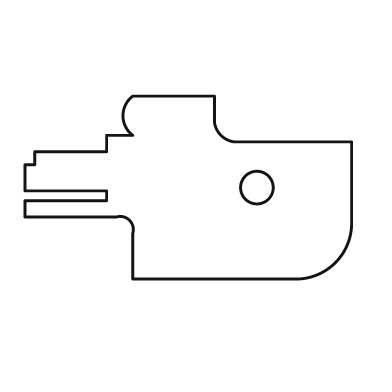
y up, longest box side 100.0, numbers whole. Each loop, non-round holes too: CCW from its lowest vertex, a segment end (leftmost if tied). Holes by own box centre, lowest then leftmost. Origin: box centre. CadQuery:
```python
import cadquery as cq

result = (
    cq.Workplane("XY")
    .moveTo(-17.0, -28.0)
    .lineTo(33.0, -28.0)
    .threePointArc((45.0, -23.0), (50.0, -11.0))
    .lineTo(50.0, 14.0)
    .lineTo(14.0, 14.0)
    .threePointArc((10.0, 16.0), (8.0, 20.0))
    .lineTo(8.0, 28.0)
    .lineTo(-17.0, 28.0)
    .threePointArc((-20.0, 22.0), (-17.0, 16.0))
    .lineTo(-25.0, 16.0)
    .lineTo(-25.0, 11.0)
    .lineTo(-47.0, 11.0)
    .lineTo(-47.0, 7.0)
    .lineTo(-50.0, 7.0)
    .lineTo(-50.0, -1.0)
    .lineTo(-25.0, -1.0)
    .lineTo(-25.0, -4.0)
    .lineTo(-50.0, -4.0)
    .lineTo(-50.0, -9.0)
    .lineTo(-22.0, -9.0)
    .threePointArc((-18.0, -10.0), (-17.0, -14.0))
    .close()
    .moveTo(21.0, 0.0)
    .circle(5.0)
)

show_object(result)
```